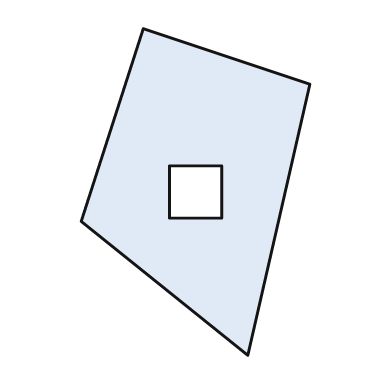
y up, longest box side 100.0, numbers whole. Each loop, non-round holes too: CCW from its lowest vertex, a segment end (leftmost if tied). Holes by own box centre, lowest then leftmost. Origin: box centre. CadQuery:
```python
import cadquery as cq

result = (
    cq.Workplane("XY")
    .moveTo(16.0, -50.0)
    .lineTo(35.0, 33.0)
    .lineTo(-16.0, 50.0)
    .lineTo(-35.0, -9.0)
    .close()
    .moveTo(-8.0, -8.0)
    .lineTo(8.0, -8.0)
    .lineTo(8.0, 8.0)
    .lineTo(-8.0, 8.0)
    .close()
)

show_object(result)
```